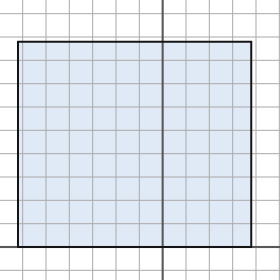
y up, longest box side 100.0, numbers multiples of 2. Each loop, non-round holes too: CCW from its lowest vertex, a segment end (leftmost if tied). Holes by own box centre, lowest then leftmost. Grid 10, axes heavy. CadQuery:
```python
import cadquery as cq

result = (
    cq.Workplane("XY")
    .moveTo(-62.0, 0.0)
    .lineTo(38.0, 0.0)
    .lineTo(38.0, 88.0)
    .lineTo(-62.0, 88.0)
    .close()
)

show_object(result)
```